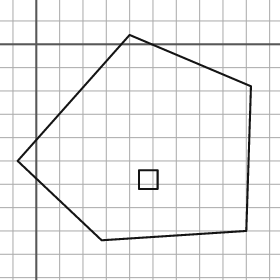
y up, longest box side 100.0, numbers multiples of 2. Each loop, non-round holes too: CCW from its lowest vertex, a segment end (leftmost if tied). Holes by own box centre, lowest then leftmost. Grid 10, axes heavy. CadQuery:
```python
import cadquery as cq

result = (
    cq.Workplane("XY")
    .moveTo(28.0, -84.0)
    .lineTo(90.0, -80.0)
    .lineTo(92.0, -18.0)
    .lineTo(40.0, 4.0)
    .lineTo(-8.0, -50.0)
    .close()
    .moveTo(44.0, -62.0)
    .lineTo(52.0, -62.0)
    .lineTo(52.0, -54.0)
    .lineTo(44.0, -54.0)
    .close()
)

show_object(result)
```